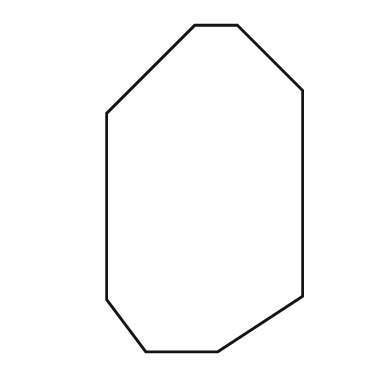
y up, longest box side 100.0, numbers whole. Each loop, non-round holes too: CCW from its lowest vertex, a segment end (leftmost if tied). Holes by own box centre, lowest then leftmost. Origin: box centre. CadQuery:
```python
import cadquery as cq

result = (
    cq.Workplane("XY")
    .moveTo(-18.0, -50.0)
    .lineTo(4.0, -50.0)
    .lineTo(30.0, -33.0)
    .lineTo(30.0, 30.0)
    .lineTo(10.0, 50.0)
    .lineTo(-3.0, 50.0)
    .lineTo(-30.0, 23.0)
    .lineTo(-30.0, -34.0)
    .close()
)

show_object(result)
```